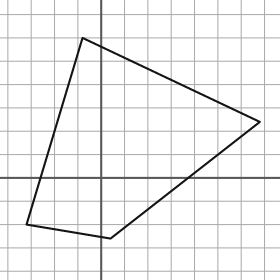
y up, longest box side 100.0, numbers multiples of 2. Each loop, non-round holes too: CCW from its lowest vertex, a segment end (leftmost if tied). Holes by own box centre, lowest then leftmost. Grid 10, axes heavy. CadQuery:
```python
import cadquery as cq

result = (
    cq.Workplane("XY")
    .moveTo(4.0, -26.0)
    .lineTo(68.0, 24.0)
    .lineTo(-8.0, 60.0)
    .lineTo(-32.0, -20.0)
    .close()
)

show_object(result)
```